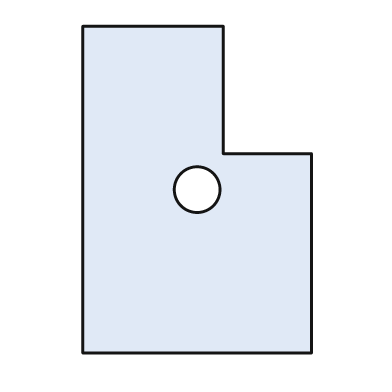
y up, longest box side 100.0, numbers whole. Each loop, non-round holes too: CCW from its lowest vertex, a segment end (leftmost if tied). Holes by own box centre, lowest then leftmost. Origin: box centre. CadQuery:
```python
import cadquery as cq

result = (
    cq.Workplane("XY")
    .moveTo(-35.0, -50.0)
    .lineTo(35.0, -50.0)
    .lineTo(35.0, 11.0)
    .lineTo(8.0, 11.0)
    .lineTo(8.0, 50.0)
    .lineTo(-35.0, 50.0)
    .close()
    .moveTo(0.0, 0.0)
    .circle(7.0)
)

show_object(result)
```